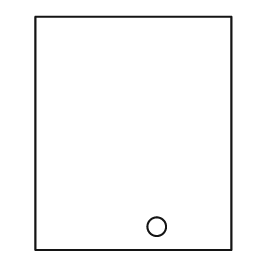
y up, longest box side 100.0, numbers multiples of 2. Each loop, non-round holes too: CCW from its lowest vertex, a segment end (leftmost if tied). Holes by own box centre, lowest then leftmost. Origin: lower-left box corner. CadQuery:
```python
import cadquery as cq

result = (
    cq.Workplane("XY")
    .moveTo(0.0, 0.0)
    .lineTo(84.0, 0.0)
    .lineTo(84.0, 100.0)
    .lineTo(0.0, 100.0)
    .close()
    .moveTo(52.0, 10.0)
    .circle(4.0)
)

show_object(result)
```